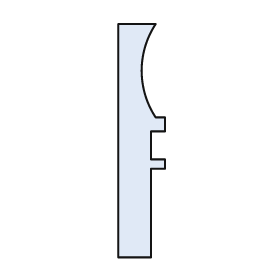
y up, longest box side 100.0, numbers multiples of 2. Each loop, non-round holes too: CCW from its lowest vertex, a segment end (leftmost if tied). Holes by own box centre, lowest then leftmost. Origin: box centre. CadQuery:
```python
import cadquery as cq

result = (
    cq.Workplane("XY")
    .moveTo(-10.0, -50.0)
    .lineTo(4.0, -50.0)
    .lineTo(4.0, -12.0)
    .lineTo(10.0, -12.0)
    .lineTo(10.0, -8.0)
    .lineTo(4.0, -8.0)
    .lineTo(4.0, 4.0)
    .lineTo(10.0, 4.0)
    .lineTo(10.0, 10.0)
    .lineTo(6.0, 10.0)
    .threePointArc((0.0, 30.0), (6.0, 50.0))
    .lineTo(-10.0, 50.0)
    .close()
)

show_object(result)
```